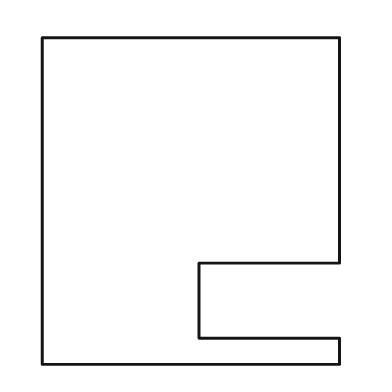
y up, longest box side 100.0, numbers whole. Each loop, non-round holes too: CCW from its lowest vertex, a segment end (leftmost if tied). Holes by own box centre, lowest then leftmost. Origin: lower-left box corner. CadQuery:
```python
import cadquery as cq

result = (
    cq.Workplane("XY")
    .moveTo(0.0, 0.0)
    .lineTo(91.0, 0.0)
    .lineTo(91.0, 8.0)
    .lineTo(48.0, 8.0)
    .lineTo(48.0, 31.0)
    .lineTo(91.0, 31.0)
    .lineTo(91.0, 100.0)
    .lineTo(0.0, 100.0)
    .close()
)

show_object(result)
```